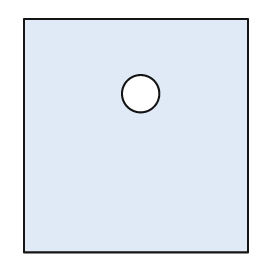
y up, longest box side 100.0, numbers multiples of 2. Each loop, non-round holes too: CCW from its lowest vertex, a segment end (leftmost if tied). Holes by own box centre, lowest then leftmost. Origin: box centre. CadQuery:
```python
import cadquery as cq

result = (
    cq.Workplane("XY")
    .moveTo(-48.0, -50.0)
    .lineTo(48.0, -50.0)
    .lineTo(48.0, 50.0)
    .lineTo(-48.0, 50.0)
    .close()
    .moveTo(2.0, 18.0)
    .circle(8.0)
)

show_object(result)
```